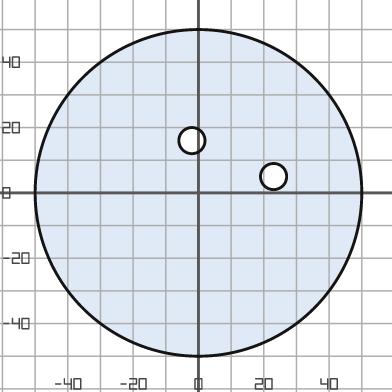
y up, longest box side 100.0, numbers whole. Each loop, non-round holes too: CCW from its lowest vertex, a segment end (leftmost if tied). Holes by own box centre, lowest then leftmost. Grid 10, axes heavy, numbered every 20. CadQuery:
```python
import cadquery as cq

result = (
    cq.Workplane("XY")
    .moveTo(0.0, 0.0)
    .circle(50.0)
    .moveTo(23.0, 5.0)
    .circle(4.0)
    .moveTo(-2.0, 16.0)
    .circle(4.0)
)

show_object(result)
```